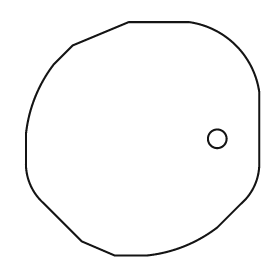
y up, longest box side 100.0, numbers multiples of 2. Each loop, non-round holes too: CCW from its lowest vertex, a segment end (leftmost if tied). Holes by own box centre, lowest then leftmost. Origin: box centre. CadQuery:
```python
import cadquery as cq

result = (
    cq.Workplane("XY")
    .moveTo(-12.0, -50.0)
    .lineTo(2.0, -50.0)
    .threePointArc((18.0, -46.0), (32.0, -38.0))
    .lineTo(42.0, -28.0)
    .threePointArc((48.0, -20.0), (50.0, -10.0))
    .lineTo(50.0, 20.0)
    .threePointArc((40.0, 40.0), (20.0, 50.0))
    .lineTo(-6.0, 50.0)
    .lineTo(-30.0, 40.0)
    .lineTo(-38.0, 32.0)
    .threePointArc((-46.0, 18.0), (-50.0, 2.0))
    .lineTo(-50.0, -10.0)
    .threePointArc((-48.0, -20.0), (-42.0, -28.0))
    .lineTo(-26.0, -44.0)
    .close()
    .moveTo(32.0, 0.0)
    .circle(4.0)
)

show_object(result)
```